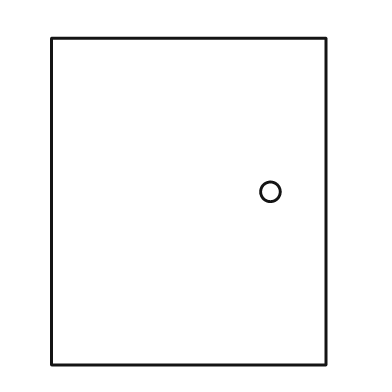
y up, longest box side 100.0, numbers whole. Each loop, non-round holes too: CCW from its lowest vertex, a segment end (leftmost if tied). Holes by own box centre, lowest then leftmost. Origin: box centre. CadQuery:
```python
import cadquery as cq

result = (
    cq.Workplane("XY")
    .moveTo(-42.0, -50.0)
    .lineTo(42.0, -50.0)
    .lineTo(42.0, 50.0)
    .lineTo(-42.0, 50.0)
    .close()
    .moveTo(25.0, 3.0)
    .circle(3.0)
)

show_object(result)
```